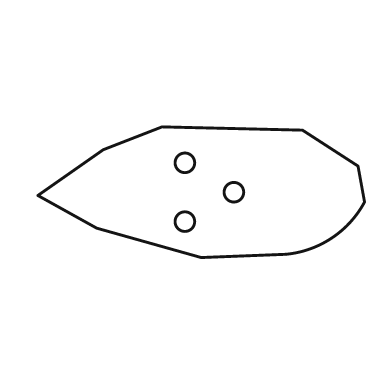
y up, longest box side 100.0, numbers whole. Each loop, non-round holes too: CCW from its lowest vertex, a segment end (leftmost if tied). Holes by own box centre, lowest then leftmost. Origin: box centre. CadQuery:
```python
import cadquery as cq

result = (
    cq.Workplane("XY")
    .moveTo(0.0, -20.0)
    .lineTo(26.0, -19.0)
    .threePointArc((40.0, -14.0), (50.0, -3.0))
    .lineTo(48.0, 8.0)
    .lineTo(31.0, 19.0)
    .lineTo(-12.0, 20.0)
    .lineTo(-30.0, 13.0)
    .lineTo(-50.0, -1.0)
    .lineTo(-32.0, -11.0)
    .close()
    .moveTo(-5.0, -9.0)
    .circle(3.0)
    .moveTo(10.0, 0.0)
    .circle(3.0)
    .moveTo(-5.0, 9.0)
    .circle(3.0)
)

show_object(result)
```